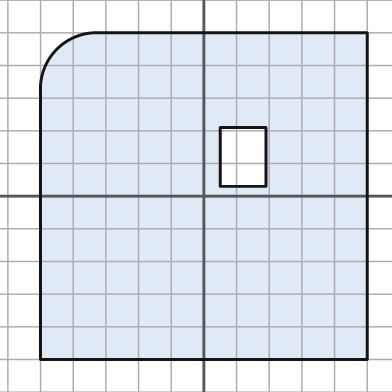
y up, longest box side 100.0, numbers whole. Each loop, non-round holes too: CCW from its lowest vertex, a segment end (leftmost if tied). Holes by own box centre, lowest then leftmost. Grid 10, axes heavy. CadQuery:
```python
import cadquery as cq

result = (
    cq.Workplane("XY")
    .moveTo(-50.0, -50.0)
    .lineTo(50.0, -50.0)
    .lineTo(50.0, 50.0)
    .lineTo(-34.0, 50.0)
    .threePointArc((-45.0, 45.0), (-50.0, 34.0))
    .close()
    .moveTo(5.0, 3.0)
    .lineTo(19.0, 3.0)
    .lineTo(19.0, 21.0)
    .lineTo(5.0, 21.0)
    .close()
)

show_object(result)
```